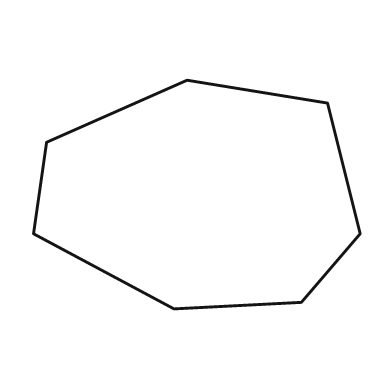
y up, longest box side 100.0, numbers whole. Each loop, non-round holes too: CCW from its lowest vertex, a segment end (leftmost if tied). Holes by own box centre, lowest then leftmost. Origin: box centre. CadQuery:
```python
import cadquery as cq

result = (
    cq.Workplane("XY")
    .moveTo(-7.0, -35.0)
    .lineTo(32.0, -33.0)
    .lineTo(50.0, -12.0)
    .lineTo(40.0, 28.0)
    .lineTo(-3.0, 35.0)
    .lineTo(-46.0, 16.0)
    .lineTo(-50.0, -12.0)
    .close()
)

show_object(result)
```